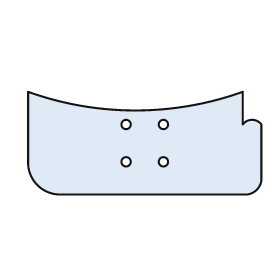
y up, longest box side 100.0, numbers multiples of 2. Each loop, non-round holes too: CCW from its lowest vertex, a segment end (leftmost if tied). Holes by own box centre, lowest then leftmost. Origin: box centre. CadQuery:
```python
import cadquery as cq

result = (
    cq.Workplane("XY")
    .moveTo(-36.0, -22.0)
    .lineTo(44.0, -22.0)
    .threePointArc((48.0, -20.0), (50.0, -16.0))
    .lineTo(50.0, 8.0)
    .threePointArc((46.0, 10.0), (42.0, 8.0))
    .lineTo(42.0, 22.0)
    .threePointArc((-4.0, 14.0), (-50.0, 22.0))
    .lineTo(-50.0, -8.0)
    .threePointArc((-46.0, -18.0), (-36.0, -22.0))
    .close()
    .moveTo(-8.0, -8.0)
    .circle(2.0)
    .moveTo(8.0, -8.0)
    .circle(2.0)
    .moveTo(-8.0, 8.0)
    .circle(2.0)
    .moveTo(8.0, 8.0)
    .circle(2.0)
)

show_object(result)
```